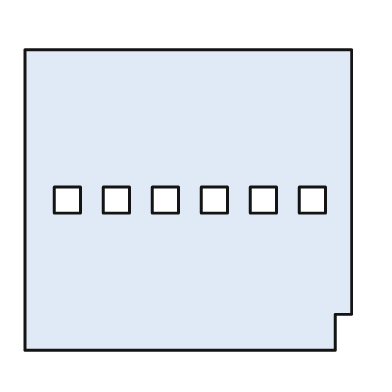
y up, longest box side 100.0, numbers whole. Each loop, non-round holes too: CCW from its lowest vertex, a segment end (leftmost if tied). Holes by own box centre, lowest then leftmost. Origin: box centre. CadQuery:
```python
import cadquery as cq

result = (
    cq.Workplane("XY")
    .moveTo(-50.0, -46.0)
    .lineTo(45.0, -46.0)
    .lineTo(45.0, -35.0)
    .lineTo(50.0, -35.0)
    .lineTo(50.0, 46.0)
    .lineTo(-50.0, 46.0)
    .close()
    .moveTo(-41.0, -4.0)
    .lineTo(-33.0, -4.0)
    .lineTo(-33.0, 4.0)
    .lineTo(-41.0, 4.0)
    .close()
    .moveTo(-26.0, -4.0)
    .lineTo(-18.0, -4.0)
    .lineTo(-18.0, 4.0)
    .lineTo(-26.0, 4.0)
    .close()
    .moveTo(-11.0, -4.0)
    .lineTo(-3.0, -4.0)
    .lineTo(-3.0, 4.0)
    .lineTo(-11.0, 4.0)
    .close()
    .moveTo(4.0, -4.0)
    .lineTo(12.0, -4.0)
    .lineTo(12.0, 4.0)
    .lineTo(4.0, 4.0)
    .close()
    .moveTo(19.0, -4.0)
    .lineTo(27.0, -4.0)
    .lineTo(27.0, 4.0)
    .lineTo(19.0, 4.0)
    .close()
    .moveTo(34.0, -4.0)
    .lineTo(42.0, -4.0)
    .lineTo(42.0, 4.0)
    .lineTo(34.0, 4.0)
    .close()
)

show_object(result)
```